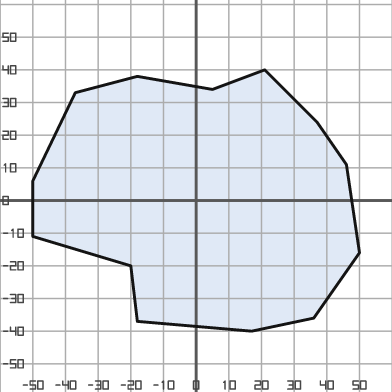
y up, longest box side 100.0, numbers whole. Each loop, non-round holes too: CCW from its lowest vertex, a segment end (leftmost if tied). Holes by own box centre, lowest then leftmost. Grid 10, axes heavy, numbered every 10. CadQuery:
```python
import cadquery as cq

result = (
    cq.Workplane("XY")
    .moveTo(17.0, -40.0)
    .lineTo(36.0, -36.0)
    .lineTo(50.0, -16.0)
    .lineTo(46.0, 11.0)
    .lineTo(37.0, 24.0)
    .lineTo(21.0, 40.0)
    .lineTo(5.0, 34.0)
    .lineTo(-18.0, 38.0)
    .lineTo(-37.0, 33.0)
    .lineTo(-50.0, 6.0)
    .lineTo(-50.0, -11.0)
    .lineTo(-20.0, -20.0)
    .lineTo(-18.0, -37.0)
    .close()
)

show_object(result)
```